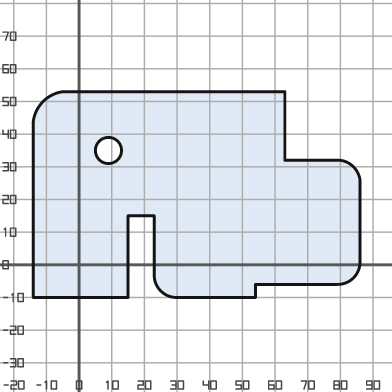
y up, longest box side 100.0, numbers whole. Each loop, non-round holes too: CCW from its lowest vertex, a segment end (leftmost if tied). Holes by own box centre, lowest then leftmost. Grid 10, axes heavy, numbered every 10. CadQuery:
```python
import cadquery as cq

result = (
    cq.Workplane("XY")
    .moveTo(-14.0, -10.0)
    .lineTo(15.0, -10.0)
    .lineTo(15.0, 15.0)
    .lineTo(23.0, 15.0)
    .lineTo(23.0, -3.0)
    .threePointArc((25.0, -8.0), (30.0, -10.0))
    .lineTo(54.0, -10.0)
    .lineTo(54.0, -6.0)
    .lineTo(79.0, -6.0)
    .threePointArc((84.0, -4.0), (86.0, 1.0))
    .lineTo(86.0, 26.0)
    .threePointArc((84.0, 30.0), (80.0, 32.0))
    .lineTo(63.0, 32.0)
    .lineTo(63.0, 53.0)
    .lineTo(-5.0, 53.0)
    .threePointArc((-11.0, 50.0), (-14.0, 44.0))
    .close()
    .moveTo(9.0, 35.0)
    .circle(4.0)
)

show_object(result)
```